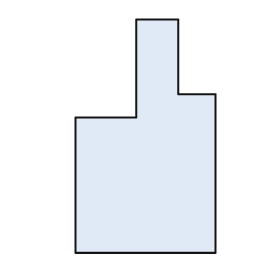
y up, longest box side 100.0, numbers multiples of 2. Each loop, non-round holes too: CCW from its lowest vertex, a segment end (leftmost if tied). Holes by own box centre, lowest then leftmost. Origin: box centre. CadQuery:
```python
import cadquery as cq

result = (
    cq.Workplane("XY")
    .moveTo(-30.0, -50.0)
    .lineTo(30.0, -50.0)
    .lineTo(30.0, 18.0)
    .lineTo(14.0, 18.0)
    .lineTo(14.0, 50.0)
    .lineTo(-4.0, 50.0)
    .lineTo(-4.0, 8.0)
    .lineTo(-30.0, 8.0)
    .close()
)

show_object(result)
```